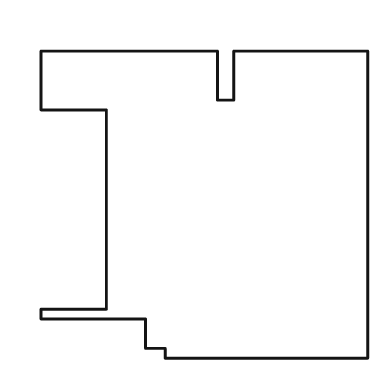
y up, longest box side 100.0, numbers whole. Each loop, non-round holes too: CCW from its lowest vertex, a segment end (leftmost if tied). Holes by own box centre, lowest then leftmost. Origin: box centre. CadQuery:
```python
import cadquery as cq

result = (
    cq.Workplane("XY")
    .moveTo(-12.0, -47.0)
    .lineTo(50.0, -47.0)
    .lineTo(50.0, 47.0)
    .lineTo(9.0, 47.0)
    .lineTo(9.0, 32.0)
    .lineTo(4.0, 32.0)
    .lineTo(4.0, 47.0)
    .lineTo(-50.0, 47.0)
    .lineTo(-50.0, 29.0)
    .lineTo(-30.0, 29.0)
    .lineTo(-30.0, -32.0)
    .lineTo(-50.0, -32.0)
    .lineTo(-50.0, -35.0)
    .lineTo(-18.0, -35.0)
    .lineTo(-18.0, -44.0)
    .lineTo(-12.0, -44.0)
    .close()
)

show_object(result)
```